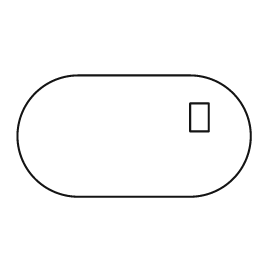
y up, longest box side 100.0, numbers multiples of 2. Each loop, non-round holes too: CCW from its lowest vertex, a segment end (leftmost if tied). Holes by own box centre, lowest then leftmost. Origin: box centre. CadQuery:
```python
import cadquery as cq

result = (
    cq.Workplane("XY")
    .moveTo(-24.0, -26.0)
    .lineTo(24.0, -26.0)
    .threePointArc((50.0, 0.0), (24.0, 26.0))
    .lineTo(-24.0, 26.0)
    .threePointArc((-50.0, 0.0), (-24.0, -26.0))
    .close()
    .moveTo(24.0, 2.0)
    .lineTo(32.0, 2.0)
    .lineTo(32.0, 14.0)
    .lineTo(24.0, 14.0)
    .close()
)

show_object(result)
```